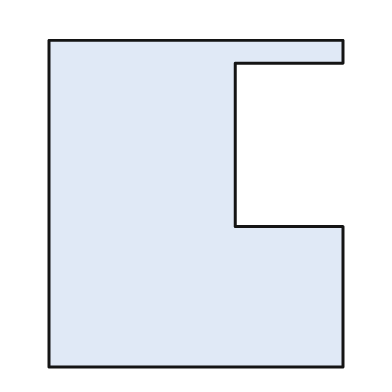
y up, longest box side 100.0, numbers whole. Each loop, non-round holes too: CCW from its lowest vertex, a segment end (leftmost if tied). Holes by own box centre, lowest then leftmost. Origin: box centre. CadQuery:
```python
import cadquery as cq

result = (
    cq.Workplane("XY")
    .moveTo(-45.0, -50.0)
    .lineTo(45.0, -50.0)
    .lineTo(45.0, -7.0)
    .lineTo(12.0, -7.0)
    .lineTo(12.0, 43.0)
    .lineTo(45.0, 43.0)
    .lineTo(45.0, 50.0)
    .lineTo(-45.0, 50.0)
    .close()
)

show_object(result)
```